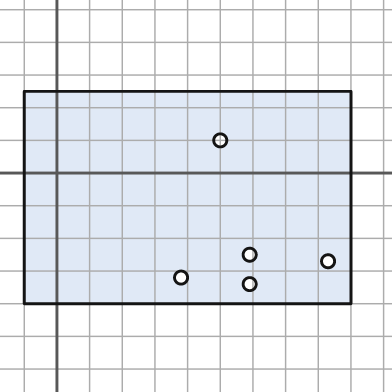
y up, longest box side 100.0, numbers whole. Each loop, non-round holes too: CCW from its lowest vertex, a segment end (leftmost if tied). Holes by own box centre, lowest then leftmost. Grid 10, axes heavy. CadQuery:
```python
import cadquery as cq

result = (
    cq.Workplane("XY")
    .moveTo(-10.0, -40.0)
    .lineTo(90.0, -40.0)
    .lineTo(90.0, 25.0)
    .lineTo(-10.0, 25.0)
    .close()
    .moveTo(59.0, -34.0)
    .circle(2.0)
    .moveTo(38.0, -32.0)
    .circle(2.0)
    .moveTo(83.0, -27.0)
    .circle(2.0)
    .moveTo(59.0, -25.0)
    .circle(2.0)
    .moveTo(50.0, 10.0)
    .circle(2.0)
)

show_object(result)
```